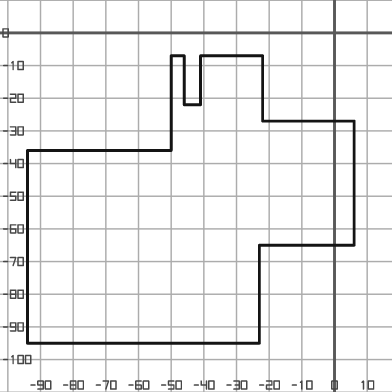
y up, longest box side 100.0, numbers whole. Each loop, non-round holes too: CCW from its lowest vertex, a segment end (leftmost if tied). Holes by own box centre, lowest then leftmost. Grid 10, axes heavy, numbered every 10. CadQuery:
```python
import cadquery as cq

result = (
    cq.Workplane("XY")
    .moveTo(-94.0, -95.0)
    .lineTo(-23.0, -95.0)
    .lineTo(-23.0, -65.0)
    .lineTo(6.0, -65.0)
    .lineTo(6.0, -27.0)
    .lineTo(-22.0, -27.0)
    .lineTo(-22.0, -7.0)
    .lineTo(-41.0, -7.0)
    .lineTo(-41.0, -22.0)
    .lineTo(-46.0, -22.0)
    .lineTo(-46.0, -7.0)
    .lineTo(-50.0, -7.0)
    .lineTo(-50.0, -36.0)
    .lineTo(-94.0, -36.0)
    .close()
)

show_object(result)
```